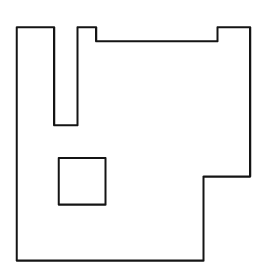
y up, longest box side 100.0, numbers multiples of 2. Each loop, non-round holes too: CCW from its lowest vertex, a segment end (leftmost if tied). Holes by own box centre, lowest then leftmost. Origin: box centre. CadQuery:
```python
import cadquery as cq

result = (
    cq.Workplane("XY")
    .moveTo(-50.0, -50.0)
    .lineTo(30.0, -50.0)
    .lineTo(30.0, -14.0)
    .lineTo(50.0, -14.0)
    .lineTo(50.0, 50.0)
    .lineTo(36.0, 50.0)
    .lineTo(36.0, 44.0)
    .lineTo(-16.0, 44.0)
    .lineTo(-16.0, 50.0)
    .lineTo(-24.0, 50.0)
    .lineTo(-24.0, 8.0)
    .lineTo(-34.0, 8.0)
    .lineTo(-34.0, 50.0)
    .lineTo(-50.0, 50.0)
    .close()
    .moveTo(-32.0, -26.0)
    .lineTo(-12.0, -26.0)
    .lineTo(-12.0, -6.0)
    .lineTo(-32.0, -6.0)
    .close()
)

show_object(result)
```